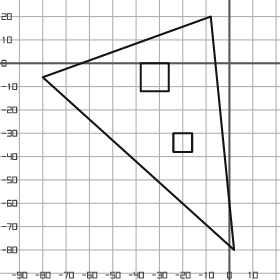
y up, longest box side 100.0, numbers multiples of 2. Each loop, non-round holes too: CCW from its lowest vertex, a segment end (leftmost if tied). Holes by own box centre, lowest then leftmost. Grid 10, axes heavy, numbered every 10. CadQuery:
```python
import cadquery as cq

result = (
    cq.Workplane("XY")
    .moveTo(2.0, -80.0)
    .lineTo(-8.0, 20.0)
    .lineTo(-80.0, -6.0)
    .close()
    .moveTo(-24.0, -38.0)
    .lineTo(-16.0, -38.0)
    .lineTo(-16.0, -30.0)
    .lineTo(-24.0, -30.0)
    .close()
    .moveTo(-38.0, -12.0)
    .lineTo(-26.0, -12.0)
    .lineTo(-26.0, 0.0)
    .lineTo(-38.0, 0.0)
    .close()
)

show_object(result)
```